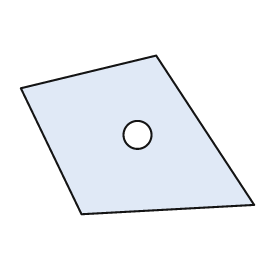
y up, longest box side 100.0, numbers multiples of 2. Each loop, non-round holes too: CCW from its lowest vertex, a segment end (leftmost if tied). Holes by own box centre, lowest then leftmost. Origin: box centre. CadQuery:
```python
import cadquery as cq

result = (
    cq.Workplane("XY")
    .moveTo(-24.0, -34.0)
    .lineTo(50.0, -30.0)
    .lineTo(8.0, 34.0)
    .lineTo(-50.0, 20.0)
    .close()
    .moveTo(0.0, 0.0)
    .circle(6.0)
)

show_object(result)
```